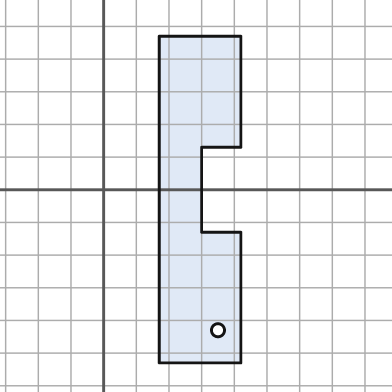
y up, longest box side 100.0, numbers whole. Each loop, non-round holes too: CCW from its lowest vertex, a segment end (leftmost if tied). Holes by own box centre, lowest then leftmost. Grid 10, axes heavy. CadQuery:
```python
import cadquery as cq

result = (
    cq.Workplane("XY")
    .moveTo(17.0, -53.0)
    .lineTo(42.0, -53.0)
    .lineTo(42.0, -13.0)
    .lineTo(30.0, -13.0)
    .lineTo(30.0, 13.0)
    .lineTo(42.0, 13.0)
    .lineTo(42.0, 47.0)
    .lineTo(17.0, 47.0)
    .close()
    .moveTo(35.0, -43.0)
    .circle(2.0)
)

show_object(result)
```